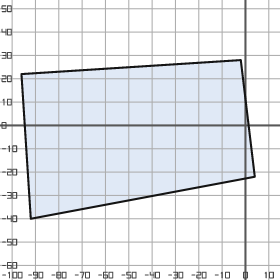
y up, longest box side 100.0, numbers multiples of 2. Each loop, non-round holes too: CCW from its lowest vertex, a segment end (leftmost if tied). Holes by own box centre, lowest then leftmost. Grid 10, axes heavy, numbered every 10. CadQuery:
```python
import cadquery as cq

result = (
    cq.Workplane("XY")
    .moveTo(-92.0, -40.0)
    .lineTo(4.0, -22.0)
    .lineTo(-2.0, 28.0)
    .lineTo(-96.0, 22.0)
    .close()
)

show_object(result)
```